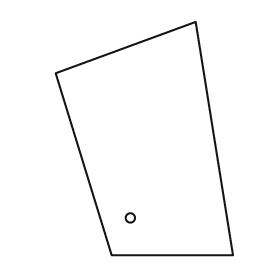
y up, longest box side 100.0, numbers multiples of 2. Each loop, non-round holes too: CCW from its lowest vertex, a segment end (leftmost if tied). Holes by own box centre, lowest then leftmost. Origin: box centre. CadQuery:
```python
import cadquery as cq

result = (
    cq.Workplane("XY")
    .moveTo(-14.0, -50.0)
    .lineTo(38.0, -50.0)
    .lineTo(22.0, 50.0)
    .lineTo(-38.0, 28.0)
    .close()
    .moveTo(-6.0, -34.0)
    .circle(2.0)
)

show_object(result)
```